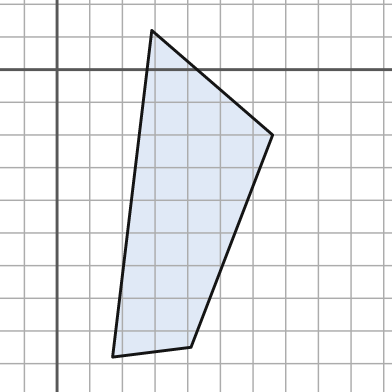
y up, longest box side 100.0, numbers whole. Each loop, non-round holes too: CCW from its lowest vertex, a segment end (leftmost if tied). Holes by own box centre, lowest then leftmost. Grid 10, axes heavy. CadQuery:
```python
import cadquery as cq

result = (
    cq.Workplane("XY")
    .moveTo(17.0, -88.0)
    .lineTo(41.0, -85.0)
    .lineTo(66.0, -20.0)
    .lineTo(29.0, 12.0)
    .close()
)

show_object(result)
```